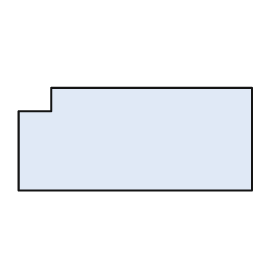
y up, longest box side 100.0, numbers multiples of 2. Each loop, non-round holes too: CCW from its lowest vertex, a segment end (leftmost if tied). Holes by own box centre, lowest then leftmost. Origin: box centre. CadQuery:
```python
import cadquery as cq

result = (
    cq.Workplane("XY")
    .moveTo(-50.0, -22.0)
    .lineTo(50.0, -22.0)
    .lineTo(50.0, 22.0)
    .lineTo(-36.0, 22.0)
    .lineTo(-36.0, 12.0)
    .lineTo(-50.0, 12.0)
    .close()
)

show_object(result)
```